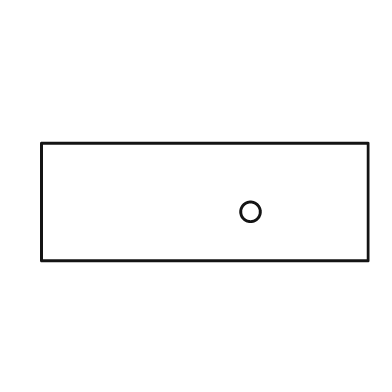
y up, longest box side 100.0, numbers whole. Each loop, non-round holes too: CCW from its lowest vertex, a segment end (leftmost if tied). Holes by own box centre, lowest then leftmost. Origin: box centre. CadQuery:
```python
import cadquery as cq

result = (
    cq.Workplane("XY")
    .moveTo(-50.0, -18.0)
    .lineTo(50.0, -18.0)
    .lineTo(50.0, 18.0)
    .lineTo(-50.0, 18.0)
    .close()
    .moveTo(14.0, -3.0)
    .circle(3.0)
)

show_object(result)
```